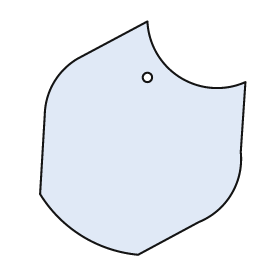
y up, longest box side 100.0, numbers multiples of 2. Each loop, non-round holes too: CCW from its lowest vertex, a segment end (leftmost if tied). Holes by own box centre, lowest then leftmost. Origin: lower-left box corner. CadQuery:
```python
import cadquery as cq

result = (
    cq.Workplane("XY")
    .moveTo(42.0, 0.0)
    .lineTo(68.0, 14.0)
    .threePointArc((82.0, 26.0), (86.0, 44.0))
    .lineTo(88.0, 74.0)
    .threePointArc((60.0, 76.0), (46.0, 100.0))
    .lineTo(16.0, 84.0)
    .threePointArc((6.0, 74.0), (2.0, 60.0))
    .lineTo(0.0, 26.0)
    .threePointArc((18.0, 8.0), (42.0, 0.0))
    .close()
    .moveTo(46.0, 76.0)
    .circle(2.0)
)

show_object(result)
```